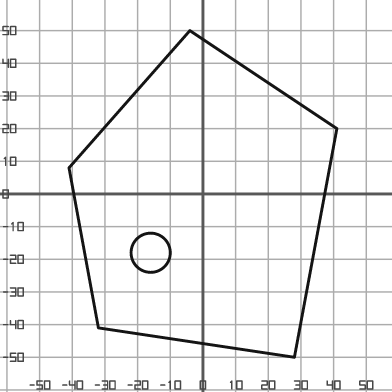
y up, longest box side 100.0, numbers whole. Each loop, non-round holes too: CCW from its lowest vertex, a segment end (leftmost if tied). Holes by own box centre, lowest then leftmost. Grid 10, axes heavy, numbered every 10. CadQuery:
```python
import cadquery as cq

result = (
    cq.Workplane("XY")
    .moveTo(28.0, -50.0)
    .lineTo(41.0, 20.0)
    .lineTo(-4.0, 50.0)
    .lineTo(-41.0, 8.0)
    .lineTo(-32.0, -41.0)
    .close()
    .moveTo(-16.0, -18.0)
    .circle(6.0)
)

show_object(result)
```